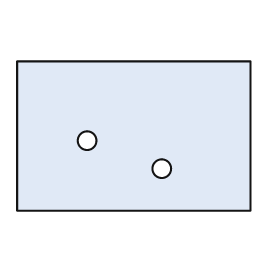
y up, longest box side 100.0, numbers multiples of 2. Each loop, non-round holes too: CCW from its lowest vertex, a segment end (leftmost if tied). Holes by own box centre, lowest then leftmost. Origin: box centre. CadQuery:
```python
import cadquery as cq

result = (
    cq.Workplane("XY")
    .moveTo(-50.0, -32.0)
    .lineTo(50.0, -32.0)
    .lineTo(50.0, 32.0)
    .lineTo(-50.0, 32.0)
    .close()
    .moveTo(12.0, -14.0)
    .circle(4.0)
    .moveTo(-20.0, -2.0)
    .circle(4.0)
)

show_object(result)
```